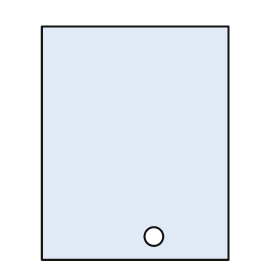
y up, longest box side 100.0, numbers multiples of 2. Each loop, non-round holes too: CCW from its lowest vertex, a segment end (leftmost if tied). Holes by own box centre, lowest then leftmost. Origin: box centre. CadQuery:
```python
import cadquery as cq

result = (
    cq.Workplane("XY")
    .moveTo(-40.0, -50.0)
    .lineTo(40.0, -50.0)
    .lineTo(40.0, 50.0)
    .lineTo(-40.0, 50.0)
    .close()
    .moveTo(8.0, -40.0)
    .circle(4.0)
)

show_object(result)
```